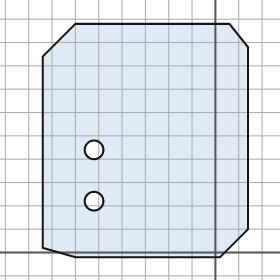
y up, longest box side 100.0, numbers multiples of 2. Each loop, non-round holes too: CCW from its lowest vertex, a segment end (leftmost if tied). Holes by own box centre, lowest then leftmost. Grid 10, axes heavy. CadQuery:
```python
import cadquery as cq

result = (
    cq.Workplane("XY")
    .moveTo(-60.0, -2.0)
    .lineTo(2.0, -2.0)
    .lineTo(14.0, 10.0)
    .lineTo(14.0, 88.0)
    .lineTo(6.0, 98.0)
    .lineTo(-60.0, 98.0)
    .lineTo(-74.0, 84.0)
    .lineTo(-74.0, 2.0)
    .close()
    .moveTo(-52.0, 22.0)
    .circle(4.0)
    .moveTo(-52.0, 44.0)
    .circle(4.0)
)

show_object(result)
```